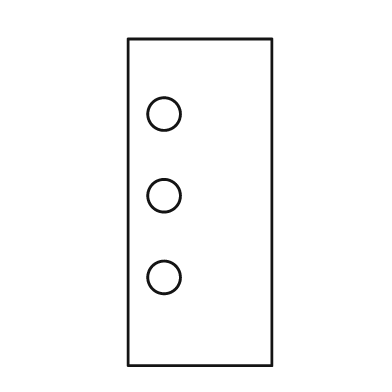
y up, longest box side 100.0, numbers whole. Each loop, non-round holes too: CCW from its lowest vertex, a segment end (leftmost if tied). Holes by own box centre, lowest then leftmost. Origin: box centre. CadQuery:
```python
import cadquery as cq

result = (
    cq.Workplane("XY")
    .moveTo(-22.0, -50.0)
    .lineTo(22.0, -50.0)
    .lineTo(22.0, 50.0)
    .lineTo(-22.0, 50.0)
    .close()
    .moveTo(-11.0, -23.0)
    .circle(5.0)
    .moveTo(-11.0, 2.0)
    .circle(5.0)
    .moveTo(-11.0, 27.0)
    .circle(5.0)
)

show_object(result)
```